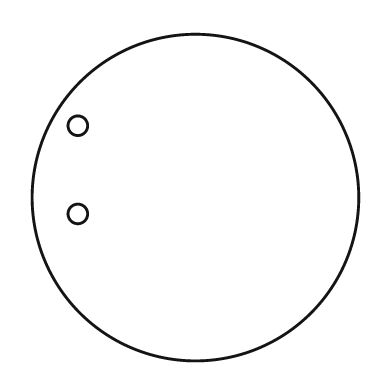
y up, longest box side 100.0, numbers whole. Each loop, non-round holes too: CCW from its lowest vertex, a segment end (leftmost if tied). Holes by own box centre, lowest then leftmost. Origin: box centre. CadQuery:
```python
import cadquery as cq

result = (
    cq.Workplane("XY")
    .moveTo(0.0, 0.0)
    .circle(50.0)
    .moveTo(-36.0, -5.0)
    .circle(3.0)
    .moveTo(-36.0, 22.0)
    .circle(3.0)
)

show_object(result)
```